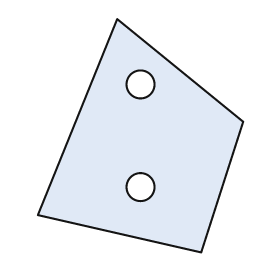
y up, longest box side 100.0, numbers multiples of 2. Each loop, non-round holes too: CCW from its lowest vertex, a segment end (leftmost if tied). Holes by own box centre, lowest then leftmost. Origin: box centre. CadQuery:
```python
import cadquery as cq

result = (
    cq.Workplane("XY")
    .moveTo(26.0, -50.0)
    .lineTo(44.0, 6.0)
    .lineTo(-10.0, 50.0)
    .lineTo(-44.0, -34.0)
    .close()
    .moveTo(0.0, -22.0)
    .circle(6.0)
    .moveTo(0.0, 22.0)
    .circle(6.0)
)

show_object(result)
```